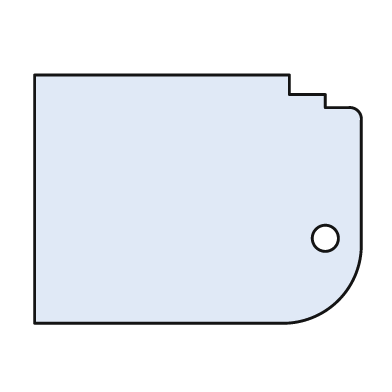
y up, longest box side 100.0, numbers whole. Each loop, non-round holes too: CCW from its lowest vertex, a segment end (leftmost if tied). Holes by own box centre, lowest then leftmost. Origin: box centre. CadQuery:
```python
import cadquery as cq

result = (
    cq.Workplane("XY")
    .moveTo(-50.0, -38.0)
    .lineTo(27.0, -38.0)
    .threePointArc((43.0, -31.0), (50.0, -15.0))
    .lineTo(50.0, 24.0)
    .threePointArc((49.0, 27.0), (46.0, 28.0))
    .lineTo(39.0, 28.0)
    .lineTo(39.0, 32.0)
    .lineTo(28.0, 32.0)
    .lineTo(28.0, 38.0)
    .lineTo(-50.0, 38.0)
    .close()
    .moveTo(39.0, -12.0)
    .circle(4.0)
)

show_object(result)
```